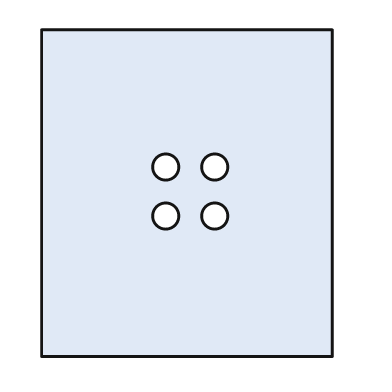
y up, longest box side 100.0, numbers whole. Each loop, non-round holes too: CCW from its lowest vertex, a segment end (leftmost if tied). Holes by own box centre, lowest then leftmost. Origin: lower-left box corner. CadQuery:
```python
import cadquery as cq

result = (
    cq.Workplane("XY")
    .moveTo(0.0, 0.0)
    .lineTo(89.0, 0.0)
    .lineTo(89.0, 100.0)
    .lineTo(0.0, 100.0)
    .close()
    .moveTo(38.0, 43.0)
    .circle(4.0)
    .moveTo(53.0, 43.0)
    .circle(4.0)
    .moveTo(38.0, 58.0)
    .circle(4.0)
    .moveTo(53.0, 58.0)
    .circle(4.0)
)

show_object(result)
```